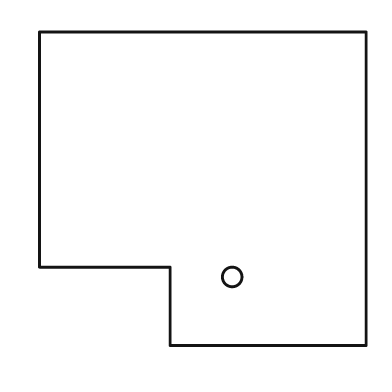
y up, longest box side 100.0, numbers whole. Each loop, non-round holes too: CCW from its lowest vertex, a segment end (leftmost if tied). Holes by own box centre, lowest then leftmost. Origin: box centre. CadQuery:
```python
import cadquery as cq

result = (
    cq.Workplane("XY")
    .moveTo(-10.0, -48.0)
    .lineTo(50.0, -48.0)
    .lineTo(50.0, 48.0)
    .lineTo(-50.0, 48.0)
    .lineTo(-50.0, -24.0)
    .lineTo(-10.0, -24.0)
    .close()
    .moveTo(9.0, -27.0)
    .circle(3.0)
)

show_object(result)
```